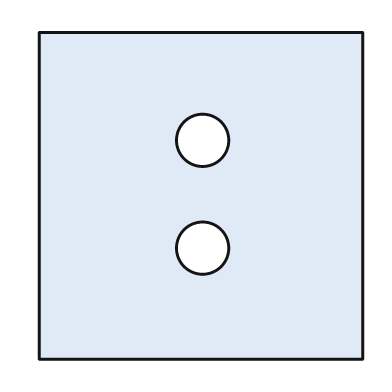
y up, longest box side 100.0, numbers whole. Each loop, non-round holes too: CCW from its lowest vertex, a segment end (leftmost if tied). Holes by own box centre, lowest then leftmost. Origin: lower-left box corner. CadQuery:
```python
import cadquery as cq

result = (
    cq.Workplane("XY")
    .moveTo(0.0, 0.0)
    .lineTo(99.0, 0.0)
    .lineTo(99.0, 100.0)
    .lineTo(0.0, 100.0)
    .close()
    .moveTo(50.0, 34.0)
    .circle(8.0)
    .moveTo(50.0, 67.0)
    .circle(8.0)
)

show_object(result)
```